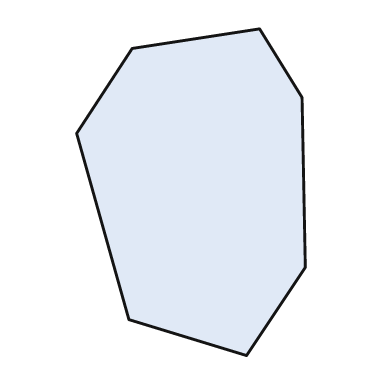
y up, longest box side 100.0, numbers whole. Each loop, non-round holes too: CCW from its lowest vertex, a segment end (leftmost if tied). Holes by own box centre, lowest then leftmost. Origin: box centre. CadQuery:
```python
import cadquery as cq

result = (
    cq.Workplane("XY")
    .moveTo(17.0, -50.0)
    .lineTo(35.0, -23.0)
    .lineTo(34.0, 29.0)
    .lineTo(21.0, 50.0)
    .lineTo(-18.0, 44.0)
    .lineTo(-35.0, 18.0)
    .lineTo(-19.0, -39.0)
    .close()
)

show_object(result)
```